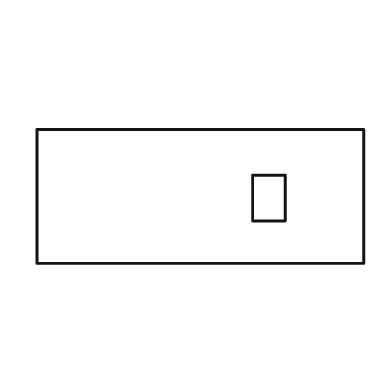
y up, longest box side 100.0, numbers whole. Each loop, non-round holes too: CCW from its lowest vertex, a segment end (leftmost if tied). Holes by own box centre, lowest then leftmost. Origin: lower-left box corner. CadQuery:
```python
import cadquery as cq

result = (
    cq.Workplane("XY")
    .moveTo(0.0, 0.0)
    .lineTo(100.0, 0.0)
    .lineTo(100.0, 41.0)
    .lineTo(0.0, 41.0)
    .close()
    .moveTo(66.0, 13.0)
    .lineTo(76.0, 13.0)
    .lineTo(76.0, 27.0)
    .lineTo(66.0, 27.0)
    .close()
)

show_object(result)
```